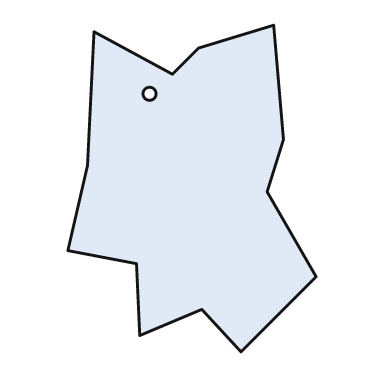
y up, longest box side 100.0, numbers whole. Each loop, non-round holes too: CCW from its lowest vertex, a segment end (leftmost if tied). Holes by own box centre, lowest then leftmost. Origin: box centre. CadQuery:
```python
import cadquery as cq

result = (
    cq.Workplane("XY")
    .moveTo(15.0, -50.0)
    .lineTo(38.0, -27.0)
    .lineTo(23.0, -1.0)
    .lineTo(28.0, 15.0)
    .lineTo(25.0, 50.0)
    .lineTo(2.0, 43.0)
    .lineTo(-6.0, 35.0)
    .lineTo(-30.0, 48.0)
    .lineTo(-32.0, 7.0)
    .lineTo(-38.0, -19.0)
    .lineTo(-17.0, -23.0)
    .lineTo(-16.0, -45.0)
    .lineTo(3.0, -37.0)
    .close()
    .moveTo(-13.0, 29.0)
    .circle(2.0)
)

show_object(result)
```